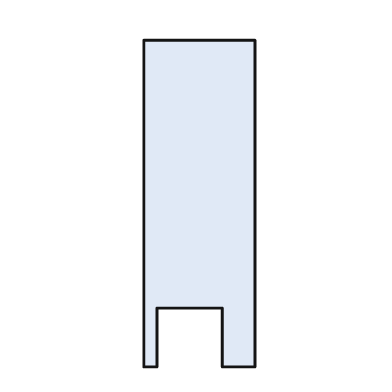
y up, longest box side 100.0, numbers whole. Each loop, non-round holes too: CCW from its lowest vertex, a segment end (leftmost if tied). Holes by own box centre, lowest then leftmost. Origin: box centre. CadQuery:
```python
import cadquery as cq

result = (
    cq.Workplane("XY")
    .moveTo(-17.0, -50.0)
    .lineTo(-13.0, -50.0)
    .lineTo(-13.0, -32.0)
    .lineTo(7.0, -32.0)
    .lineTo(7.0, -50.0)
    .lineTo(17.0, -50.0)
    .lineTo(17.0, 50.0)
    .lineTo(-17.0, 50.0)
    .close()
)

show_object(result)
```